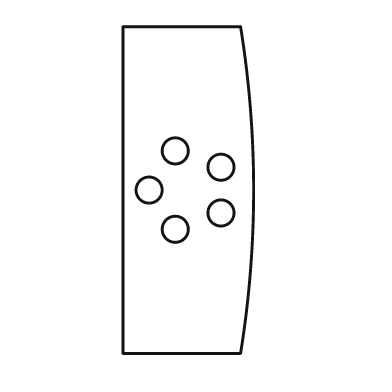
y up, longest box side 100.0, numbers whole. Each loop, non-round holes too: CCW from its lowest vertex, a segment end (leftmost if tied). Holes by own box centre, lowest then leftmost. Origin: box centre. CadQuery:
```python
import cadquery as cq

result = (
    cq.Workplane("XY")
    .moveTo(-20.0, -50.0)
    .lineTo(16.0, -50.0)
    .threePointArc((20.0, 0.0), (16.0, 50.0))
    .lineTo(-20.0, 50.0)
    .close()
    .moveTo(-4.0, -12.0)
    .circle(4.0)
    .moveTo(10.0, -7.0)
    .circle(4.0)
    .moveTo(-12.0, 0.0)
    .circle(4.0)
    .moveTo(10.0, 7.0)
    .circle(4.0)
    .moveTo(-4.0, 12.0)
    .circle(4.0)
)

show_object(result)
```